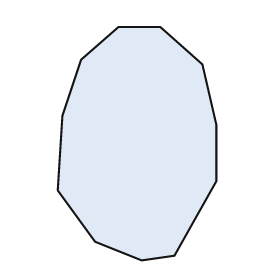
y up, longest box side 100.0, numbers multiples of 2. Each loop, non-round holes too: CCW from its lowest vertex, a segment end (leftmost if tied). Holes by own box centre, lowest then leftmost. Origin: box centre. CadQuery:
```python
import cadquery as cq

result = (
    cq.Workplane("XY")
    .moveTo(2.0, -50.0)
    .lineTo(16.0, -48.0)
    .lineTo(34.0, -16.0)
    .lineTo(34.0, 8.0)
    .lineTo(28.0, 34.0)
    .lineTo(10.0, 50.0)
    .lineTo(-8.0, 50.0)
    .lineTo(-24.0, 36.0)
    .lineTo(-32.0, 12.0)
    .lineTo(-34.0, -20.0)
    .lineTo(-18.0, -42.0)
    .close()
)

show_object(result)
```